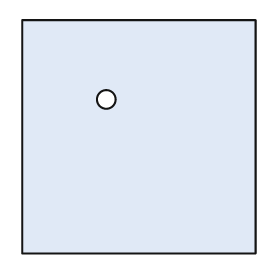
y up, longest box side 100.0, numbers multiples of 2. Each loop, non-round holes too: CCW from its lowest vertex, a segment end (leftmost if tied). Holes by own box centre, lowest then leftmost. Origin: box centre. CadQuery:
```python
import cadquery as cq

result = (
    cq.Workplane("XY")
    .moveTo(-50.0, -50.0)
    .lineTo(50.0, -50.0)
    .lineTo(50.0, 50.0)
    .lineTo(-50.0, 50.0)
    .close()
    .moveTo(-14.0, 16.0)
    .circle(4.0)
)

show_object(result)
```